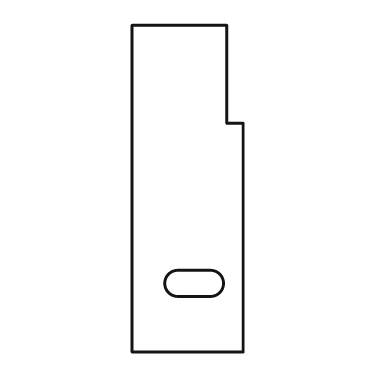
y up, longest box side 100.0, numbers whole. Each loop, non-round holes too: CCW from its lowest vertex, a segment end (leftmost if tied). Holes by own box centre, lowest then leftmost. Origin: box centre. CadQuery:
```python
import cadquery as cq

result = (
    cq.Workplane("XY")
    .moveTo(-17.0, -50.0)
    .lineTo(17.0, -50.0)
    .lineTo(17.0, 20.0)
    .lineTo(12.0, 20.0)
    .lineTo(12.0, 50.0)
    .lineTo(-17.0, 50.0)
    .close()
    .moveTo(-3.0, -33.0)
    .lineTo(7.0, -33.0)
    .threePointArc((11.0, -29.0), (7.0, -25.0))
    .lineTo(-3.0, -25.0)
    .threePointArc((-7.0, -29.0), (-3.0, -33.0))
    .close()
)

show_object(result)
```